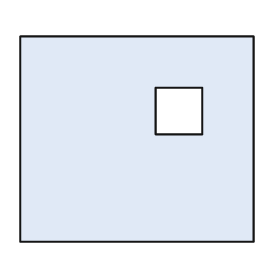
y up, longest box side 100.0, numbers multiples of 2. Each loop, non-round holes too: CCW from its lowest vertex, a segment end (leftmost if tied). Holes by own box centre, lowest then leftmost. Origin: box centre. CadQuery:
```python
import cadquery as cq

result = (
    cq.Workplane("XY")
    .moveTo(-50.0, -44.0)
    .lineTo(50.0, -44.0)
    .lineTo(50.0, 44.0)
    .lineTo(-50.0, 44.0)
    .close()
    .moveTo(8.0, 2.0)
    .lineTo(28.0, 2.0)
    .lineTo(28.0, 22.0)
    .lineTo(8.0, 22.0)
    .close()
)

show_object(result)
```